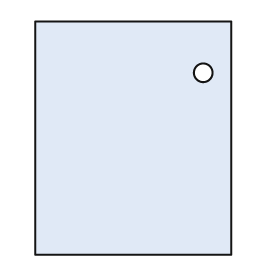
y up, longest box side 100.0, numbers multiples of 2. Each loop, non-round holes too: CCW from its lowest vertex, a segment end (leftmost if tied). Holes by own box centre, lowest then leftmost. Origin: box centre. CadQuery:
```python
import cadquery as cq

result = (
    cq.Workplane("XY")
    .moveTo(-42.0, -50.0)
    .lineTo(42.0, -50.0)
    .lineTo(42.0, 50.0)
    .lineTo(-42.0, 50.0)
    .close()
    .moveTo(30.0, 28.0)
    .circle(4.0)
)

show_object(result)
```